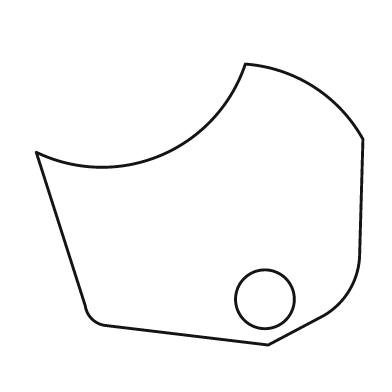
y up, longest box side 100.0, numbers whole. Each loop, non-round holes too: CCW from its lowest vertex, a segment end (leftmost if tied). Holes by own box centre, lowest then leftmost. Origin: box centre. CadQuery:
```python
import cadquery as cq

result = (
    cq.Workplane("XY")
    .moveTo(21.0, -43.0)
    .lineTo(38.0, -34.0)
    .threePointArc((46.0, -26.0), (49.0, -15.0))
    .lineTo(50.0, 20.0)
    .threePointArc((35.0, 36.0), (14.0, 43.0))
    .threePointArc((-12.0, 15.0), (-50.0, 16.0))
    .lineTo(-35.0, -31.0)
    .threePointArc((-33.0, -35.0), (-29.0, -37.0))
    .close()
    .moveTo(20.0, -29.0)
    .circle(9.0)
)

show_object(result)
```